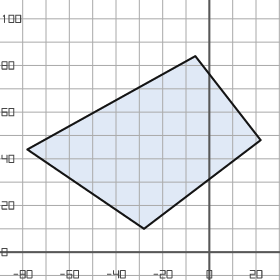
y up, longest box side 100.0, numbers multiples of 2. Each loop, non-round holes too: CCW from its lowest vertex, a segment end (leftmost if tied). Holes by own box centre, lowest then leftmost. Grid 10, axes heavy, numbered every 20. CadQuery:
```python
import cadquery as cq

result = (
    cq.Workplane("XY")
    .moveTo(-28.0, 10.0)
    .lineTo(22.0, 48.0)
    .lineTo(-6.0, 84.0)
    .lineTo(-78.0, 44.0)
    .close()
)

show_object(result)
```